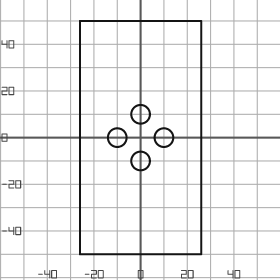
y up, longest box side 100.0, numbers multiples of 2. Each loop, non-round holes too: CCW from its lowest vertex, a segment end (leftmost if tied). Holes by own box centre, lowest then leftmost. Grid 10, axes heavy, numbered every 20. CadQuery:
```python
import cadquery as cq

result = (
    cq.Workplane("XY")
    .moveTo(-26.0, -50.0)
    .lineTo(26.0, -50.0)
    .lineTo(26.0, 50.0)
    .lineTo(-26.0, 50.0)
    .close()
    .moveTo(0.0, -10.0)
    .circle(4.0)
    .moveTo(-10.0, 0.0)
    .circle(4.0)
    .moveTo(10.0, 0.0)
    .circle(4.0)
    .moveTo(0.0, 10.0)
    .circle(4.0)
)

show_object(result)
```